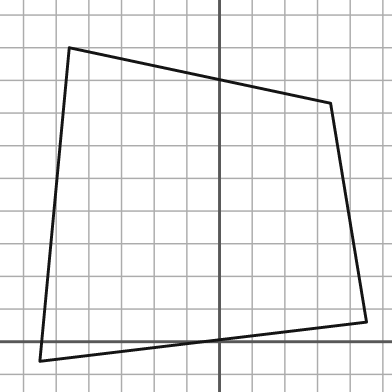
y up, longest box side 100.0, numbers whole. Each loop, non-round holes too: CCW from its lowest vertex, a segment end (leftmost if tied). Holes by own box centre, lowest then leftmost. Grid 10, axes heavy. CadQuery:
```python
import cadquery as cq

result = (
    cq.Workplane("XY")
    .moveTo(-55.0, -6.0)
    .lineTo(45.0, 6.0)
    .lineTo(34.0, 73.0)
    .lineTo(-46.0, 90.0)
    .close()
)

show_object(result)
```